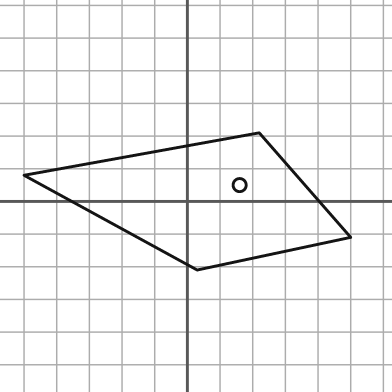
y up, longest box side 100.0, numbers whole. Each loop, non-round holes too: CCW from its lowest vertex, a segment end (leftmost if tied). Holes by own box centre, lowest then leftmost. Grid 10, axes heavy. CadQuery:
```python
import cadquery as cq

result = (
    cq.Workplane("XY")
    .moveTo(3.0, -21.0)
    .lineTo(50.0, -11.0)
    .lineTo(22.0, 21.0)
    .lineTo(-50.0, 8.0)
    .close()
    .moveTo(16.0, 5.0)
    .circle(2.0)
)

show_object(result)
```